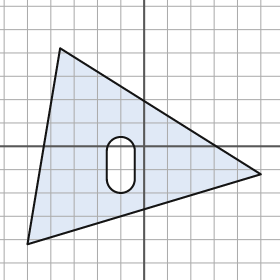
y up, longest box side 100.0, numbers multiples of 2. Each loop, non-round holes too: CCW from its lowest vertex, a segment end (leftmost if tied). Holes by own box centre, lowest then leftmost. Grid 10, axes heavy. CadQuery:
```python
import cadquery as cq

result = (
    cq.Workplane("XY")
    .moveTo(-50.0, -42.0)
    .lineTo(50.0, -12.0)
    .lineTo(-36.0, 42.0)
    .close()
    .moveTo(-16.0, -14.0)
    .threePointArc((-10.0, -20.0), (-4.0, -14.0))
    .lineTo(-4.0, -2.0)
    .threePointArc((-10.0, 4.0), (-16.0, -2.0))
    .close()
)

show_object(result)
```